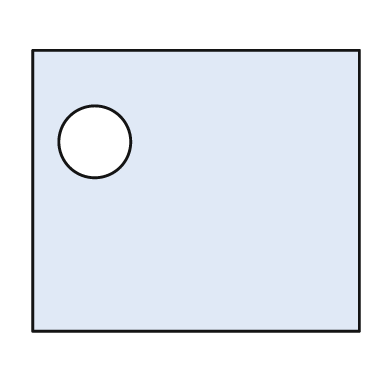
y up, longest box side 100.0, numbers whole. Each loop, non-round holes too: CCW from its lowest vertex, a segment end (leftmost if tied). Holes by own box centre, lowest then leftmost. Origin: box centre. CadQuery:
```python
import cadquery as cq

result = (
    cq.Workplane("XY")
    .moveTo(-50.0, -43.0)
    .lineTo(50.0, -43.0)
    .lineTo(50.0, 43.0)
    .lineTo(-50.0, 43.0)
    .close()
    .moveTo(-31.0, 15.0)
    .circle(11.0)
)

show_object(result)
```